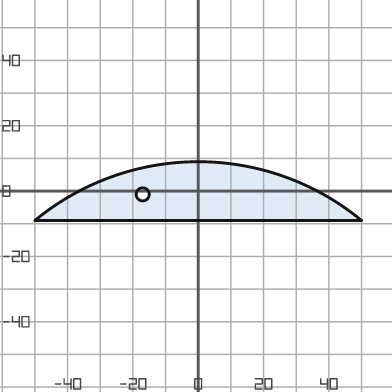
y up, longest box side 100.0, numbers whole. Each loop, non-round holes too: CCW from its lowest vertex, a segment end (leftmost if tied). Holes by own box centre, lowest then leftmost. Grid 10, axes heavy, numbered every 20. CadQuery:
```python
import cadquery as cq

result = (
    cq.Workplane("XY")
    .moveTo(-50.0, -9.0)
    .lineTo(50.0, -9.0)
    .threePointArc((0.0, 9.0), (-50.0, -9.0))
    .close()
    .moveTo(-17.0, -1.0)
    .circle(2.0)
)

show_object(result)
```